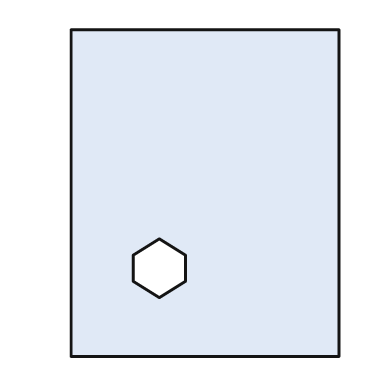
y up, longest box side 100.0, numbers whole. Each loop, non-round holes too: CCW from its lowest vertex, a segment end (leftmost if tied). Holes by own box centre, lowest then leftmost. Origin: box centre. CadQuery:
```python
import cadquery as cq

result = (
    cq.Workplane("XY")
    .moveTo(-41.0, -50.0)
    .lineTo(41.0, -50.0)
    .lineTo(41.0, 50.0)
    .lineTo(-41.0, 50.0)
    .close()
    .moveTo(-14.0, -32.0)
    .lineTo(-6.0, -27.0)
    .lineTo(-6.0, -19.0)
    .lineTo(-14.0, -14.0)
    .lineTo(-22.0, -19.0)
    .lineTo(-22.0, -27.0)
    .close()
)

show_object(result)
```